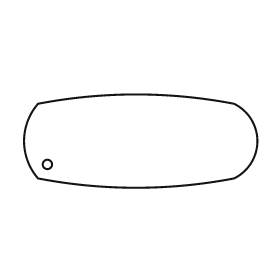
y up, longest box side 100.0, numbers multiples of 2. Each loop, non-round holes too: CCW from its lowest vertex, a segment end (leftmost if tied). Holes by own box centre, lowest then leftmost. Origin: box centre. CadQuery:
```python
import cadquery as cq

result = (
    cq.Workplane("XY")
    .moveTo(-44.0, -16.0)
    .threePointArc((-2.0, -20.0), (40.0, -16.0))
    .threePointArc((50.0, 0.0), (40.0, 16.0))
    .threePointArc((-2.0, 20.0), (-44.0, 16.0))
    .threePointArc((-50.0, 0.0), (-44.0, -16.0))
    .close()
    .moveTo(-40.0, -10.0)
    .circle(2.0)
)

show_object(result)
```